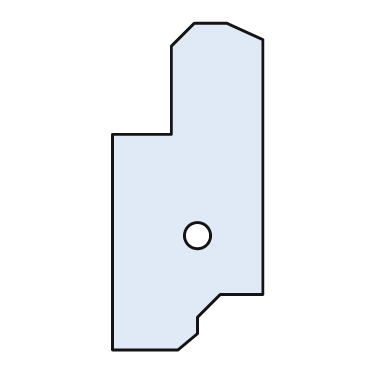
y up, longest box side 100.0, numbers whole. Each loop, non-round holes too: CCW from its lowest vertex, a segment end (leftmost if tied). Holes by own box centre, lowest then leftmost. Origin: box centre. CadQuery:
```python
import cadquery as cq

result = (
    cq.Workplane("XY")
    .moveTo(-23.0, -50.0)
    .lineTo(-3.0, -50.0)
    .lineTo(3.0, -45.0)
    .lineTo(3.0, -40.0)
    .lineTo(10.0, -33.0)
    .lineTo(23.0, -33.0)
    .lineTo(23.0, 45.0)
    .lineTo(12.0, 50.0)
    .lineTo(2.0, 50.0)
    .lineTo(-5.0, 43.0)
    .lineTo(-5.0, 16.0)
    .lineTo(-23.0, 16.0)
    .close()
    .moveTo(3.0, -15.0)
    .circle(4.0)
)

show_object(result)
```